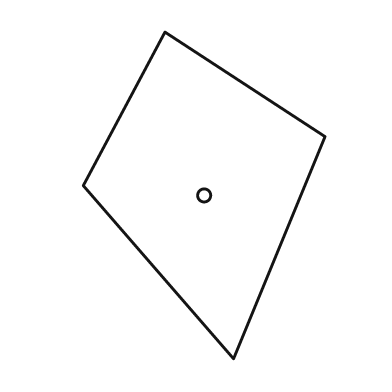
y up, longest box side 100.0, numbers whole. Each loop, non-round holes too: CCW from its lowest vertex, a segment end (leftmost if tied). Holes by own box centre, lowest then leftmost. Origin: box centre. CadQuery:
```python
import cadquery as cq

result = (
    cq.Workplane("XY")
    .moveTo(9.0, -50.0)
    .lineTo(37.0, 18.0)
    .lineTo(-12.0, 50.0)
    .lineTo(-37.0, 3.0)
    .close()
    .moveTo(0.0, 0.0)
    .circle(2.0)
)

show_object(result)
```